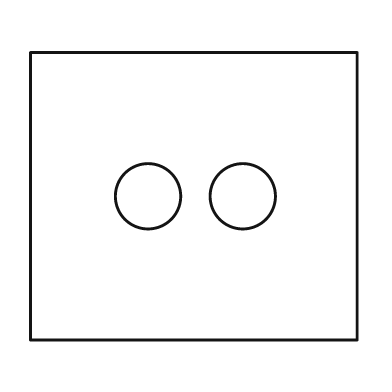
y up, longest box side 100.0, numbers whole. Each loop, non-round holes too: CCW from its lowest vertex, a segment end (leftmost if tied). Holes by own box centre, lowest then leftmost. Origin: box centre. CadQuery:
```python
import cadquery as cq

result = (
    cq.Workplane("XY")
    .moveTo(-50.0, -44.0)
    .lineTo(50.0, -44.0)
    .lineTo(50.0, 44.0)
    .lineTo(-50.0, 44.0)
    .close()
    .moveTo(-14.0, 0.0)
    .circle(10.0)
    .moveTo(15.0, 0.0)
    .circle(10.0)
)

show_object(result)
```